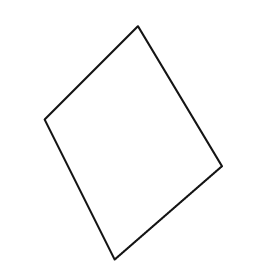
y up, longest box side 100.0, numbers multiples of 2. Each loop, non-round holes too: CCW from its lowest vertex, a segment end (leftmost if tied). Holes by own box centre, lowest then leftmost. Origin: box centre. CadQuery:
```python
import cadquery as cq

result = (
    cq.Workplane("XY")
    .moveTo(-8.0, -50.0)
    .lineTo(38.0, -10.0)
    .lineTo(2.0, 50.0)
    .lineTo(-38.0, 10.0)
    .close()
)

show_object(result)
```